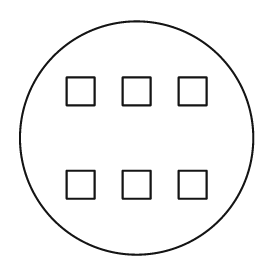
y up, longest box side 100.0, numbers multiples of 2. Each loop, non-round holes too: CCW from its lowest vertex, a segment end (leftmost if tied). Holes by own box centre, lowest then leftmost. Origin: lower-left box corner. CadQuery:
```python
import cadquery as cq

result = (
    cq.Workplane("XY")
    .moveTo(50.0, 50.0)
    .circle(50.0)
    .moveTo(20.0, 24.0)
    .lineTo(32.0, 24.0)
    .lineTo(32.0, 36.0)
    .lineTo(20.0, 36.0)
    .close()
    .moveTo(44.0, 24.0)
    .lineTo(56.0, 24.0)
    .lineTo(56.0, 36.0)
    .lineTo(44.0, 36.0)
    .close()
    .moveTo(68.0, 24.0)
    .lineTo(80.0, 24.0)
    .lineTo(80.0, 36.0)
    .lineTo(68.0, 36.0)
    .close()
    .moveTo(20.0, 64.0)
    .lineTo(32.0, 64.0)
    .lineTo(32.0, 76.0)
    .lineTo(20.0, 76.0)
    .close()
    .moveTo(44.0, 64.0)
    .lineTo(56.0, 64.0)
    .lineTo(56.0, 76.0)
    .lineTo(44.0, 76.0)
    .close()
    .moveTo(68.0, 64.0)
    .lineTo(80.0, 64.0)
    .lineTo(80.0, 76.0)
    .lineTo(68.0, 76.0)
    .close()
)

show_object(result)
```